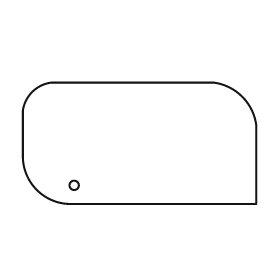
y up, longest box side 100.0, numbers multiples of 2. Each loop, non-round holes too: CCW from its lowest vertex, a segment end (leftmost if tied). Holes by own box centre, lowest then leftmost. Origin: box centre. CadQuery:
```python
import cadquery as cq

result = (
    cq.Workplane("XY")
    .moveTo(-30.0, -26.0)
    .lineTo(50.0, -26.0)
    .lineTo(50.0, 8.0)
    .threePointArc((44.0, 20.0), (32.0, 26.0))
    .lineTo(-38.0, 26.0)
    .threePointArc((-46.0, 22.0), (-50.0, 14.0))
    .lineTo(-50.0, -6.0)
    .threePointArc((-44.0, -20.0), (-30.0, -26.0))
    .close()
    .moveTo(-28.0, -18.0)
    .circle(2.0)
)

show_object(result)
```